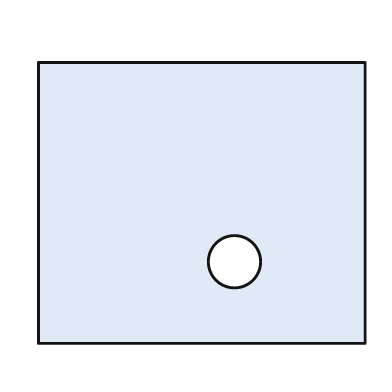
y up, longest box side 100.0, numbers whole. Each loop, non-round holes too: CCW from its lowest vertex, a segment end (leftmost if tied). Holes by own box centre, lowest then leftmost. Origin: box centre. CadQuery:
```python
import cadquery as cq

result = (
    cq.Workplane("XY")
    .moveTo(-50.0, -43.0)
    .lineTo(50.0, -43.0)
    .lineTo(50.0, 43.0)
    .lineTo(-50.0, 43.0)
    .close()
    .moveTo(10.0, -18.0)
    .circle(8.0)
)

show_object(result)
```